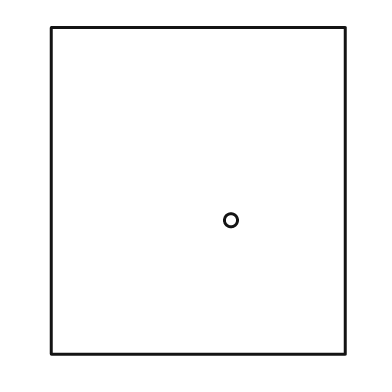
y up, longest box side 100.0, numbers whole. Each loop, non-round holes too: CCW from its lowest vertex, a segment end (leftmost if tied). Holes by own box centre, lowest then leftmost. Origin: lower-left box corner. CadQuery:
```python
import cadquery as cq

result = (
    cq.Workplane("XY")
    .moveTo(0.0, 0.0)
    .lineTo(90.0, 0.0)
    .lineTo(90.0, 100.0)
    .lineTo(0.0, 100.0)
    .close()
    .moveTo(55.0, 41.0)
    .circle(2.0)
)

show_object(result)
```